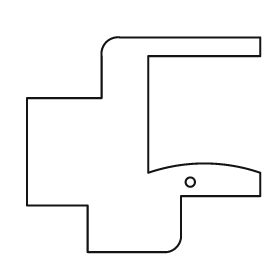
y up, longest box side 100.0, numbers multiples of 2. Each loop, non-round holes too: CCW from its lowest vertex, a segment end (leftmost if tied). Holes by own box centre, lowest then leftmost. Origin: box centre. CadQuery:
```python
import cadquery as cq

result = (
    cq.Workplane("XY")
    .moveTo(-24.0, -46.0)
    .lineTo(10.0, -46.0)
    .threePointArc((14.0, -44.0), (16.0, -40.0))
    .lineTo(16.0, -22.0)
    .lineTo(50.0, -22.0)
    .lineTo(50.0, -12.0)
    .threePointArc((26.0, -8.0), (2.0, -12.0))
    .lineTo(2.0, 38.0)
    .lineTo(50.0, 38.0)
    .lineTo(50.0, 46.0)
    .lineTo(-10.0, 46.0)
    .threePointArc((-16.0, 44.0), (-18.0, 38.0))
    .lineTo(-18.0, 20.0)
    .lineTo(-50.0, 20.0)
    .lineTo(-50.0, -26.0)
    .lineTo(-24.0, -26.0)
    .close()
    .moveTo(20.0, -16.0)
    .circle(2.0)
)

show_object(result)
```